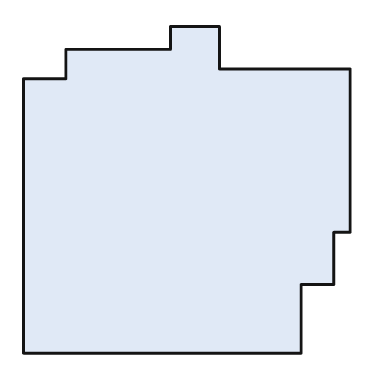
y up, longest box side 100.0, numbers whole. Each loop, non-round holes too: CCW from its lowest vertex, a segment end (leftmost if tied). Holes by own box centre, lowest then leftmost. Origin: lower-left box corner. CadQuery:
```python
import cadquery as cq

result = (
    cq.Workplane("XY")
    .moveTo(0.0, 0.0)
    .lineTo(85.0, 0.0)
    .lineTo(85.0, 21.0)
    .lineTo(95.0, 21.0)
    .lineTo(95.0, 37.0)
    .lineTo(100.0, 37.0)
    .lineTo(100.0, 87.0)
    .lineTo(60.0, 87.0)
    .lineTo(60.0, 100.0)
    .lineTo(45.0, 100.0)
    .lineTo(45.0, 93.0)
    .lineTo(13.0, 93.0)
    .lineTo(13.0, 84.0)
    .lineTo(0.0, 84.0)
    .close()
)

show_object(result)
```